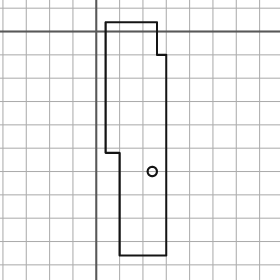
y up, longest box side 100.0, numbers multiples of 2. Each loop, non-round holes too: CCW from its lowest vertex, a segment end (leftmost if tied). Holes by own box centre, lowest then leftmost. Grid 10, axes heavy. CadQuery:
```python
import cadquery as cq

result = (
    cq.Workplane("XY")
    .moveTo(10.0, -96.0)
    .lineTo(30.0, -96.0)
    .lineTo(30.0, -10.0)
    .lineTo(26.0, -10.0)
    .lineTo(26.0, 4.0)
    .lineTo(4.0, 4.0)
    .lineTo(4.0, -52.0)
    .lineTo(10.0, -52.0)
    .close()
    .moveTo(24.0, -60.0)
    .circle(2.0)
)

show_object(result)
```